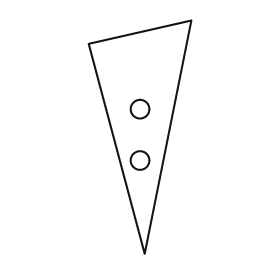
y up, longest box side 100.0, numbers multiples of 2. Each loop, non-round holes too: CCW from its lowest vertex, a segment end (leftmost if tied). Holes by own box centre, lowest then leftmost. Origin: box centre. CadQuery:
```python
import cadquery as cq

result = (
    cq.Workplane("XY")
    .moveTo(2.0, -50.0)
    .lineTo(22.0, 50.0)
    .lineTo(-22.0, 40.0)
    .close()
    .moveTo(0.0, -10.0)
    .circle(4.0)
    .moveTo(0.0, 12.0)
    .circle(4.0)
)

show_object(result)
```